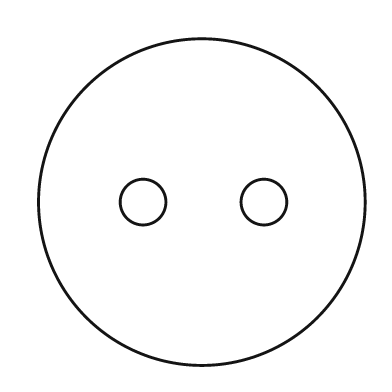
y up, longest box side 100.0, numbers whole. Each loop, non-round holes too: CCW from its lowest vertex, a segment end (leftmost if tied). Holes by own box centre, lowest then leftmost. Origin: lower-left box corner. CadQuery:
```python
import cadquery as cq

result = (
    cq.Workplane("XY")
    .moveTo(50.0, 50.0)
    .circle(50.0)
    .moveTo(32.0, 50.0)
    .circle(7.0)
    .moveTo(69.0, 50.0)
    .circle(7.0)
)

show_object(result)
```